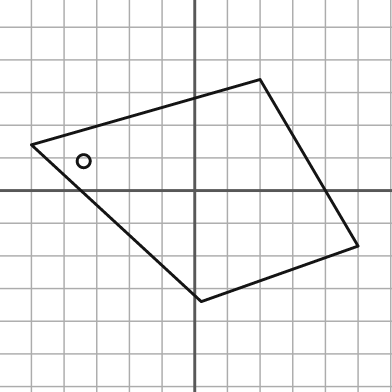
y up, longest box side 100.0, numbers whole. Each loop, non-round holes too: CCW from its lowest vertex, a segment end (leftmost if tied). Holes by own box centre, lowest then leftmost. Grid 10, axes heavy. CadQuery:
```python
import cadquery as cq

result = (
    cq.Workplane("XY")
    .moveTo(2.0, -34.0)
    .lineTo(50.0, -17.0)
    .lineTo(20.0, 34.0)
    .lineTo(-50.0, 14.0)
    .close()
    .moveTo(-34.0, 9.0)
    .circle(2.0)
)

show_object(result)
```